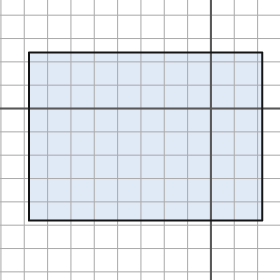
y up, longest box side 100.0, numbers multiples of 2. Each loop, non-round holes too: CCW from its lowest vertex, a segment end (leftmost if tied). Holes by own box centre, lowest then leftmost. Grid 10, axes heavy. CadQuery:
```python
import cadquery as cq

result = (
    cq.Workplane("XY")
    .moveTo(-78.0, -48.0)
    .lineTo(22.0, -48.0)
    .lineTo(22.0, 24.0)
    .lineTo(-78.0, 24.0)
    .close()
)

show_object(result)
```